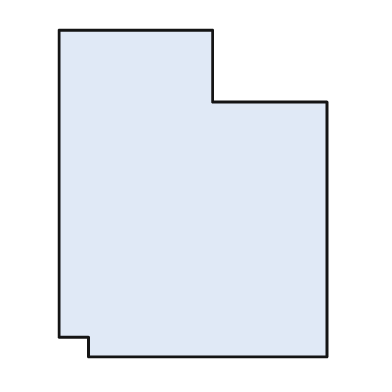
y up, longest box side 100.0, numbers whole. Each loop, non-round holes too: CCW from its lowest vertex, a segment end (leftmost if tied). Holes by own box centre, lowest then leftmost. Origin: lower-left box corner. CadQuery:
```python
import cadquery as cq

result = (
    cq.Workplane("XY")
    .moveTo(9.0, 0.0)
    .lineTo(82.0, 0.0)
    .lineTo(82.0, 78.0)
    .lineTo(47.0, 78.0)
    .lineTo(47.0, 100.0)
    .lineTo(0.0, 100.0)
    .lineTo(0.0, 6.0)
    .lineTo(9.0, 6.0)
    .close()
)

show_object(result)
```